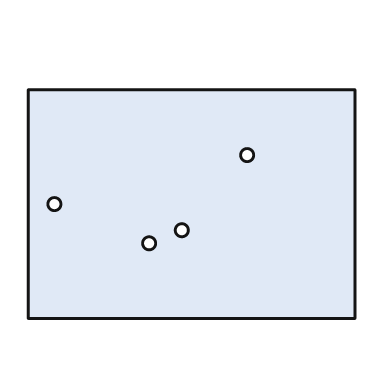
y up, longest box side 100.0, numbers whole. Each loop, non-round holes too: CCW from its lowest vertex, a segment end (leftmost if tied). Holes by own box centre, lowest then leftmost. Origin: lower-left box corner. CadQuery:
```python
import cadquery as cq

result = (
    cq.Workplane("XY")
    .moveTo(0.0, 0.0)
    .lineTo(100.0, 0.0)
    .lineTo(100.0, 70.0)
    .lineTo(0.0, 70.0)
    .close()
    .moveTo(37.0, 23.0)
    .circle(2.0)
    .moveTo(47.0, 27.0)
    .circle(2.0)
    .moveTo(8.0, 35.0)
    .circle(2.0)
    .moveTo(67.0, 50.0)
    .circle(2.0)
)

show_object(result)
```